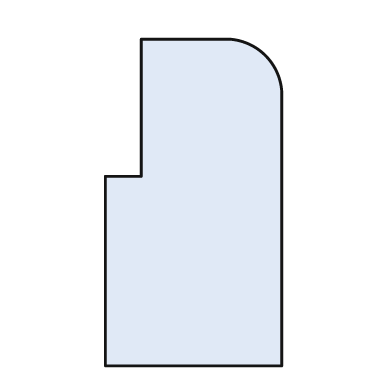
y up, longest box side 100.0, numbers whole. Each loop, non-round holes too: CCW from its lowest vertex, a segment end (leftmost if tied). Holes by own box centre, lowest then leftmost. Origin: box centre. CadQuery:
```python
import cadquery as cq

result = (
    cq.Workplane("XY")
    .moveTo(-27.0, -50.0)
    .lineTo(27.0, -50.0)
    .lineTo(27.0, 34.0)
    .threePointArc((22.0, 45.0), (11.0, 50.0))
    .lineTo(-16.0, 50.0)
    .lineTo(-16.0, 8.0)
    .lineTo(-27.0, 8.0)
    .close()
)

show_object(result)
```